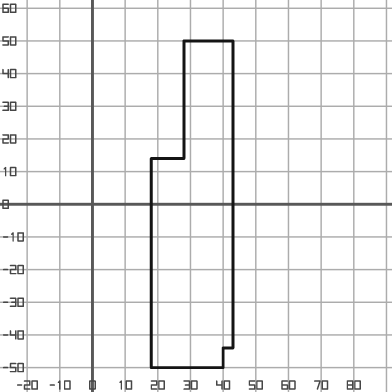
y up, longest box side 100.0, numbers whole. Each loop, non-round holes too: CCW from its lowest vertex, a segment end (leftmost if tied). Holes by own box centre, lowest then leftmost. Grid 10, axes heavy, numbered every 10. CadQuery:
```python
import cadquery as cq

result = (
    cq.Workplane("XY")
    .moveTo(18.0, -50.0)
    .lineTo(40.0, -50.0)
    .lineTo(40.0, -44.0)
    .lineTo(43.0, -44.0)
    .lineTo(43.0, 50.0)
    .lineTo(28.0, 50.0)
    .lineTo(28.0, 14.0)
    .lineTo(18.0, 14.0)
    .close()
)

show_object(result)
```